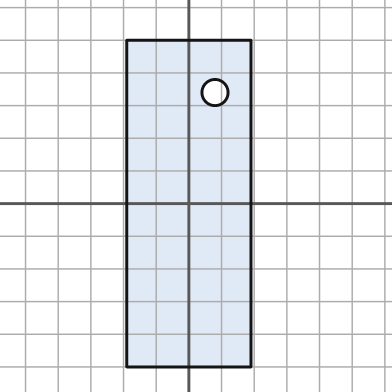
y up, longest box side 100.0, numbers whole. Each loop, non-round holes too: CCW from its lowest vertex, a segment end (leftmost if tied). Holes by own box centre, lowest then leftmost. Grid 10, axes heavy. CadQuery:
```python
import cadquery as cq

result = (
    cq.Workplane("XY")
    .moveTo(-19.0, -50.0)
    .lineTo(19.0, -50.0)
    .lineTo(19.0, 50.0)
    .lineTo(-19.0, 50.0)
    .close()
    .moveTo(8.0, 34.0)
    .circle(4.0)
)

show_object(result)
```